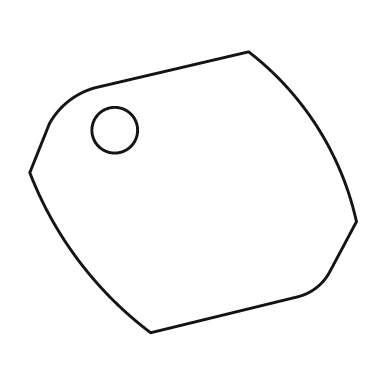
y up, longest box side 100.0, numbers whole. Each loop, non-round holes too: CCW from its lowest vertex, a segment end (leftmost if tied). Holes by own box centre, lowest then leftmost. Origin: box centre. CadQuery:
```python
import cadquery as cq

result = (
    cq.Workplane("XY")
    .moveTo(-13.0, -43.0)
    .lineTo(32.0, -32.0)
    .threePointArc((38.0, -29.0), (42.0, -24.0))
    .lineTo(50.0, -9.0)
    .threePointArc((38.0, 20.0), (17.0, 43.0))
    .lineTo(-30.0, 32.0)
    .threePointArc((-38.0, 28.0), (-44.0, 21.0))
    .lineTo(-50.0, 6.0)
    .threePointArc((-35.0, -21.0), (-13.0, -43.0))
    .close()
    .moveTo(-24.0, 19.0)
    .circle(7.0)
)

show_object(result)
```